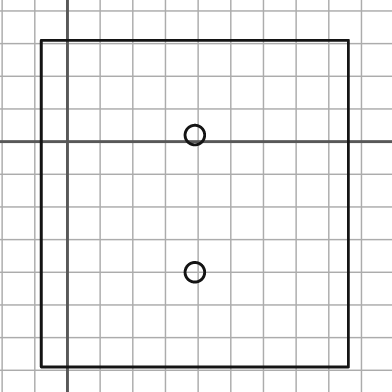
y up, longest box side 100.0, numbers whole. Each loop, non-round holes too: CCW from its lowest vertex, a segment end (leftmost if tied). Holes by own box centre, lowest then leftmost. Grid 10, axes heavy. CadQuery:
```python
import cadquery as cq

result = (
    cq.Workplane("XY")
    .moveTo(-8.0, -69.0)
    .lineTo(86.0, -69.0)
    .lineTo(86.0, 31.0)
    .lineTo(-8.0, 31.0)
    .close()
    .moveTo(39.0, -40.0)
    .circle(3.0)
    .moveTo(39.0, 2.0)
    .circle(3.0)
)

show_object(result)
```